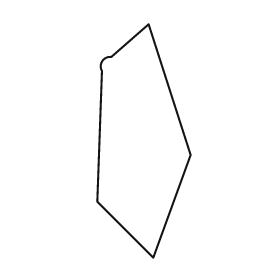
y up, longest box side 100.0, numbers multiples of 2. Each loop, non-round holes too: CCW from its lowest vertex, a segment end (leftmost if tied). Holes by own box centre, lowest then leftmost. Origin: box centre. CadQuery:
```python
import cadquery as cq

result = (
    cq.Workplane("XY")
    .moveTo(4.0, -50.0)
    .lineTo(20.0, -6.0)
    .lineTo(2.0, 50.0)
    .lineTo(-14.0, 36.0)
    .threePointArc((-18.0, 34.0), (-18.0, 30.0))
    .lineTo(-20.0, -26.0)
    .close()
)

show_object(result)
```